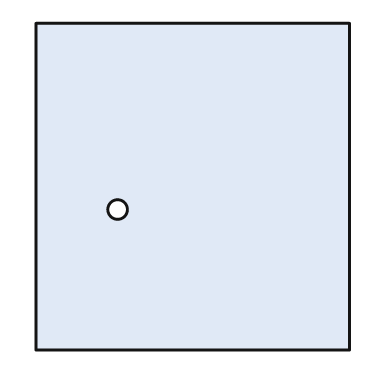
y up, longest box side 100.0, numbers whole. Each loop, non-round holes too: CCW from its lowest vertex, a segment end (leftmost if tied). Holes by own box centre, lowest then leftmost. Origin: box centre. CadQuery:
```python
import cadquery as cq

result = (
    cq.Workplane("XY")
    .moveTo(-48.0, -50.0)
    .lineTo(48.0, -50.0)
    .lineTo(48.0, 50.0)
    .lineTo(-48.0, 50.0)
    .close()
    .moveTo(-23.0, -7.0)
    .circle(3.0)
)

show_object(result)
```